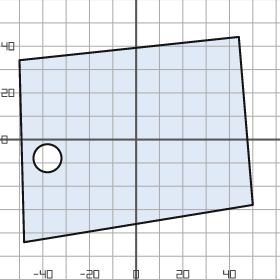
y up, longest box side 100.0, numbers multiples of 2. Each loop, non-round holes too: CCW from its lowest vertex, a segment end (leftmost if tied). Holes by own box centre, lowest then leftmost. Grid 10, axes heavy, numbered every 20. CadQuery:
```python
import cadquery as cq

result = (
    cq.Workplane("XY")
    .moveTo(-48.0, -44.0)
    .lineTo(50.0, -28.0)
    .lineTo(44.0, 44.0)
    .lineTo(-50.0, 34.0)
    .close()
    .moveTo(-38.0, -8.0)
    .circle(6.0)
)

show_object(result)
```